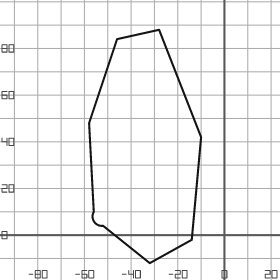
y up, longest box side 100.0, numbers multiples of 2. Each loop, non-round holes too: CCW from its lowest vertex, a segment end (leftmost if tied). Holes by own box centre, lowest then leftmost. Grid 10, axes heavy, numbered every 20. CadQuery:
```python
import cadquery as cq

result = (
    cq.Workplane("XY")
    .moveTo(-32.0, -12.0)
    .lineTo(-14.0, -2.0)
    .lineTo(-10.0, 42.0)
    .lineTo(-28.0, 88.0)
    .lineTo(-46.0, 84.0)
    .lineTo(-58.0, 48.0)
    .lineTo(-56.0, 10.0)
    .threePointArc((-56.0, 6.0), (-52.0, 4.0))
    .close()
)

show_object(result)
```